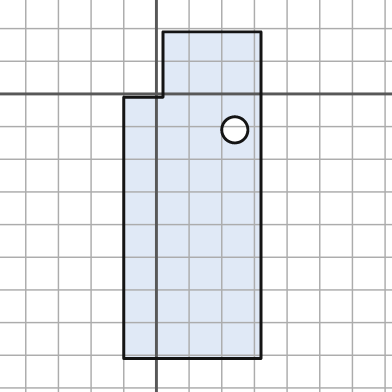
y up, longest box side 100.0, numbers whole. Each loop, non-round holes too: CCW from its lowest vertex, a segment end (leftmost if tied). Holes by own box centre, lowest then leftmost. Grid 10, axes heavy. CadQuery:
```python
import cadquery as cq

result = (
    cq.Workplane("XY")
    .moveTo(-10.0, -81.0)
    .lineTo(32.0, -81.0)
    .lineTo(32.0, 19.0)
    .lineTo(2.0, 19.0)
    .lineTo(2.0, -1.0)
    .lineTo(-10.0, -1.0)
    .close()
    .moveTo(24.0, -11.0)
    .circle(4.0)
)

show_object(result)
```